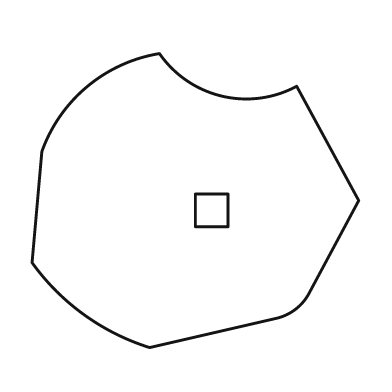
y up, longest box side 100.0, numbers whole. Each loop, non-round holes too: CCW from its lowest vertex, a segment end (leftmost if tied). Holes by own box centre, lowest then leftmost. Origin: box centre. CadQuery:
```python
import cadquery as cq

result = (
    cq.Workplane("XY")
    .moveTo(-14.0, -45.0)
    .lineTo(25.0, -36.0)
    .threePointArc((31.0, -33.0), (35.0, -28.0))
    .lineTo(50.0, 0.0)
    .lineTo(31.0, 35.0)
    .threePointArc((8.0, 32.0), (-11.0, 45.0))
    .threePointArc((-33.0, 35.0), (-47.0, 15.0))
    .lineTo(-50.0, -19.0)
    .threePointArc((-34.0, -35.0), (-14.0, -45.0))
    .close()
    .moveTo(0.0, -8.0)
    .lineTo(10.0, -8.0)
    .lineTo(10.0, 2.0)
    .lineTo(0.0, 2.0)
    .close()
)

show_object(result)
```